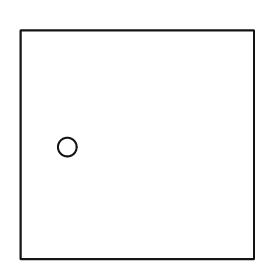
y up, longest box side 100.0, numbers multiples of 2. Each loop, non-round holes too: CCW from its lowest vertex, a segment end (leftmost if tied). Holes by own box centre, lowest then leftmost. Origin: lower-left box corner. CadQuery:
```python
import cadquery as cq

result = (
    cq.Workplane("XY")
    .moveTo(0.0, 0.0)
    .lineTo(100.0, 0.0)
    .lineTo(100.0, 98.0)
    .lineTo(0.0, 98.0)
    .close()
    .moveTo(20.0, 48.0)
    .circle(4.0)
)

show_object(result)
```